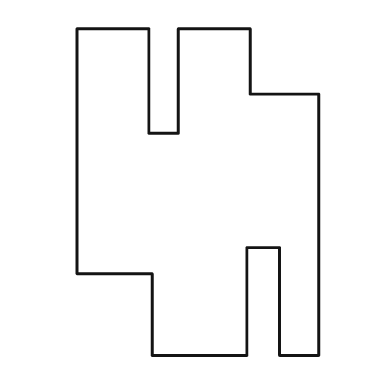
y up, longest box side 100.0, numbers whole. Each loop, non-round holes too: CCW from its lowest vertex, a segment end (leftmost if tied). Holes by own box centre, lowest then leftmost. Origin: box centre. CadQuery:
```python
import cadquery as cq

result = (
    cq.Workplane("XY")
    .moveTo(-14.0, -50.0)
    .lineTo(15.0, -50.0)
    .lineTo(15.0, -17.0)
    .lineTo(25.0, -17.0)
    .lineTo(25.0, -50.0)
    .lineTo(37.0, -50.0)
    .lineTo(37.0, 30.0)
    .lineTo(16.0, 30.0)
    .lineTo(16.0, 50.0)
    .lineTo(-6.0, 50.0)
    .lineTo(-6.0, 18.0)
    .lineTo(-15.0, 18.0)
    .lineTo(-15.0, 50.0)
    .lineTo(-37.0, 50.0)
    .lineTo(-37.0, -25.0)
    .lineTo(-14.0, -25.0)
    .close()
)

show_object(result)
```